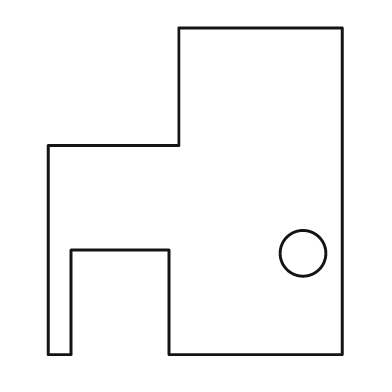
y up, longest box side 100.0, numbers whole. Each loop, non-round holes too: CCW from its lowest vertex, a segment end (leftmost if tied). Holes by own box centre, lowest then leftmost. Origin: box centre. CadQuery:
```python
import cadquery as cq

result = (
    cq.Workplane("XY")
    .moveTo(-45.0, -50.0)
    .lineTo(-38.0, -50.0)
    .lineTo(-38.0, -18.0)
    .lineTo(-8.0, -18.0)
    .lineTo(-8.0, -50.0)
    .lineTo(45.0, -50.0)
    .lineTo(45.0, 50.0)
    .lineTo(-5.0, 50.0)
    .lineTo(-5.0, 14.0)
    .lineTo(-45.0, 14.0)
    .close()
    .moveTo(33.0, -19.0)
    .circle(7.0)
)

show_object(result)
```